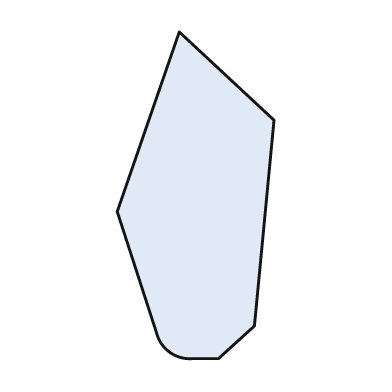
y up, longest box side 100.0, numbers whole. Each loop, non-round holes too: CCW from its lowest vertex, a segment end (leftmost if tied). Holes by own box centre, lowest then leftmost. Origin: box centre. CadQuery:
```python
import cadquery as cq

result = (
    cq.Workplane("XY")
    .moveTo(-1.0, -50.0)
    .lineTo(7.0, -50.0)
    .lineTo(18.0, -40.0)
    .lineTo(24.0, 23.0)
    .lineTo(-5.0, 50.0)
    .lineTo(-24.0, -5.0)
    .lineTo(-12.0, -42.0)
    .threePointArc((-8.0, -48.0), (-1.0, -50.0))
    .close()
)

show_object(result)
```